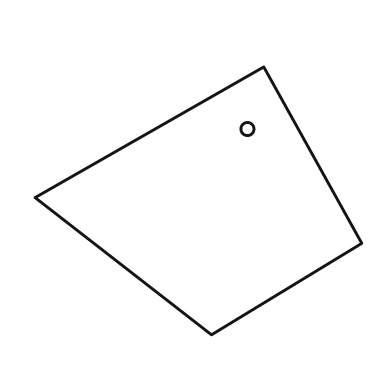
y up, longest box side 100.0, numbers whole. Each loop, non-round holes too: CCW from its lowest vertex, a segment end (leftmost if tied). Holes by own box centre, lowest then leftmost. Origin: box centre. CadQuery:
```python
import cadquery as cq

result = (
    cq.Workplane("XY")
    .moveTo(4.0, -41.0)
    .lineTo(50.0, -13.0)
    .lineTo(20.0, 41.0)
    .lineTo(-50.0, 1.0)
    .close()
    .moveTo(15.0, 22.0)
    .circle(2.0)
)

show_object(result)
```